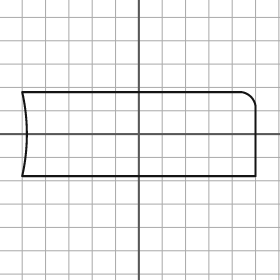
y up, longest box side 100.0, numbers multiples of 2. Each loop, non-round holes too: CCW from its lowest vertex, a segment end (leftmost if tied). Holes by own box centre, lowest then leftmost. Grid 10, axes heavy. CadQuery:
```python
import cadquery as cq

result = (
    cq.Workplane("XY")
    .moveTo(-50.0, -18.0)
    .lineTo(50.0, -18.0)
    .lineTo(50.0, 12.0)
    .threePointArc((48.0, 16.0), (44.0, 18.0))
    .lineTo(-50.0, 18.0)
    .threePointArc((-48.0, 0.0), (-50.0, -18.0))
    .close()
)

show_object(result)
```